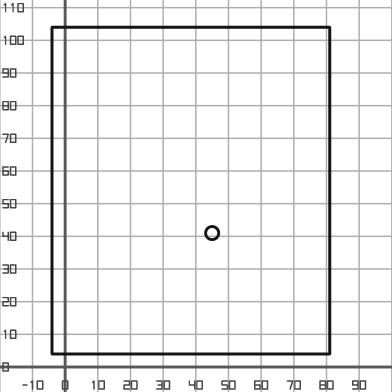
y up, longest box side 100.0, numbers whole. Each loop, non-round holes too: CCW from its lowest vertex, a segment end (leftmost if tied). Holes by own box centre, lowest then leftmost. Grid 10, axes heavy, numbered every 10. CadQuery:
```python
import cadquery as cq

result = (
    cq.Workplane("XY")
    .moveTo(-4.0, 4.0)
    .lineTo(81.0, 4.0)
    .lineTo(81.0, 104.0)
    .lineTo(-4.0, 104.0)
    .close()
    .moveTo(45.0, 41.0)
    .circle(2.0)
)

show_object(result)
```